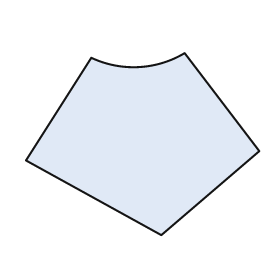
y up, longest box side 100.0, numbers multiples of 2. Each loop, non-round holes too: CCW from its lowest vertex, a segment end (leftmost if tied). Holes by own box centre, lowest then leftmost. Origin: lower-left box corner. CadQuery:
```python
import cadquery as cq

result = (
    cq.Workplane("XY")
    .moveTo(58.0, 0.0)
    .lineTo(100.0, 36.0)
    .lineTo(68.0, 78.0)
    .threePointArc((48.0, 72.0), (28.0, 76.0))
    .lineTo(0.0, 32.0)
    .close()
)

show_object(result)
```